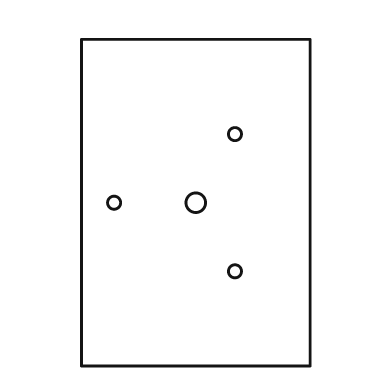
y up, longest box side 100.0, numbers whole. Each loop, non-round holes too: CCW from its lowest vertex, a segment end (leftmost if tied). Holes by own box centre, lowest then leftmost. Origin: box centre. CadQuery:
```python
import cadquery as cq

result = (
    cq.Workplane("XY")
    .moveTo(-35.0, -50.0)
    .lineTo(35.0, -50.0)
    .lineTo(35.0, 50.0)
    .lineTo(-35.0, 50.0)
    .close()
    .moveTo(12.0, -21.0)
    .circle(2.0)
    .moveTo(-25.0, 0.0)
    .circle(2.0)
    .moveTo(0.0, 0.0)
    .circle(3.0)
    .moveTo(12.0, 21.0)
    .circle(2.0)
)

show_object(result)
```